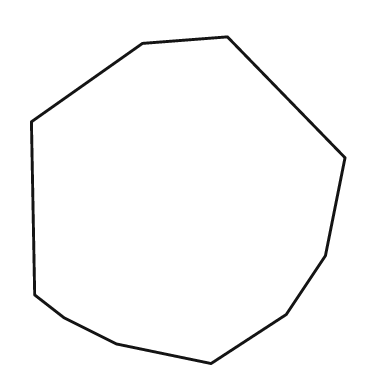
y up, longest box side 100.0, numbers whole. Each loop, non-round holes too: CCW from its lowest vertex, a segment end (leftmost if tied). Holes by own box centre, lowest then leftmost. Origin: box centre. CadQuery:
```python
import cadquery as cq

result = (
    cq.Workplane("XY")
    .moveTo(7.0, -50.0)
    .lineTo(30.0, -35.0)
    .lineTo(42.0, -17.0)
    .lineTo(48.0, 13.0)
    .lineTo(12.0, 50.0)
    .lineTo(-14.0, 48.0)
    .lineTo(-48.0, 24.0)
    .lineTo(-47.0, -29.0)
    .lineTo(-38.0, -36.0)
    .lineTo(-22.0, -44.0)
    .close()
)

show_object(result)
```